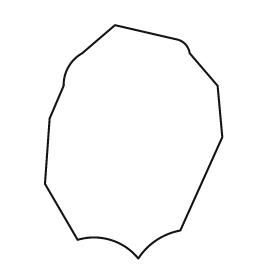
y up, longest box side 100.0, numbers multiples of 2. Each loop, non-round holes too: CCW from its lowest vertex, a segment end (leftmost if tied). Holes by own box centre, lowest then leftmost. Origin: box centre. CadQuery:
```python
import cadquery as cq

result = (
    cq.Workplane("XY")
    .moveTo(2.0, -50.0)
    .threePointArc((10.0, -42.0), (20.0, -38.0))
    .lineTo(38.0, 2.0)
    .lineTo(36.0, 24.0)
    .lineTo(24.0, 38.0)
    .threePointArc((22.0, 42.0), (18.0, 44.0))
    .lineTo(-8.0, 50.0)
    .lineTo(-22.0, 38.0)
    .threePointArc((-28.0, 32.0), (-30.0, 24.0))
    .lineTo(-36.0, 10.0)
    .lineTo(-38.0, -18.0)
    .lineTo(-24.0, -42.0)
    .threePointArc((-10.0, -42.0), (2.0, -50.0))
    .close()
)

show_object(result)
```